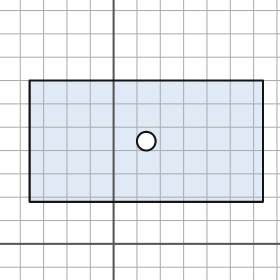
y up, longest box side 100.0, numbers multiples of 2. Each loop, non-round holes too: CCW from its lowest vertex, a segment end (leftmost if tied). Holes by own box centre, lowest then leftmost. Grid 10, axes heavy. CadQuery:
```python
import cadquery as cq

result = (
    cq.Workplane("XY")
    .moveTo(-36.0, 18.0)
    .lineTo(64.0, 18.0)
    .lineTo(64.0, 70.0)
    .lineTo(-36.0, 70.0)
    .close()
    .moveTo(14.0, 44.0)
    .circle(4.0)
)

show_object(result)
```